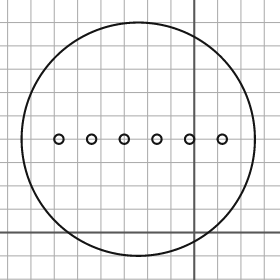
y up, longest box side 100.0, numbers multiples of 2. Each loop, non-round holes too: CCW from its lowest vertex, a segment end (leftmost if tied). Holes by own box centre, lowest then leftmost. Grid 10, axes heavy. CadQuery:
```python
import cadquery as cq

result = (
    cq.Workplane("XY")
    .moveTo(-24.0, 40.0)
    .circle(50.0)
    .moveTo(-58.0, 40.0)
    .circle(2.0)
    .moveTo(-44.0, 40.0)
    .circle(2.0)
    .moveTo(-30.0, 40.0)
    .circle(2.0)
    .moveTo(-16.0, 40.0)
    .circle(2.0)
    .moveTo(-2.0, 40.0)
    .circle(2.0)
    .moveTo(12.0, 40.0)
    .circle(2.0)
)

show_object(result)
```